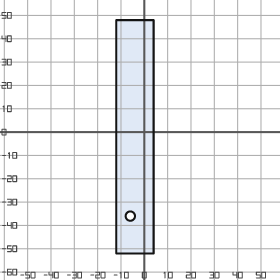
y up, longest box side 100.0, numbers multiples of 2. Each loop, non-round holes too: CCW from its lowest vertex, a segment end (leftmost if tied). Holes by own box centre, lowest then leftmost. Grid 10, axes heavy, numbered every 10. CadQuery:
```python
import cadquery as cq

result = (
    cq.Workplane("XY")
    .moveTo(-12.0, -52.0)
    .lineTo(4.0, -52.0)
    .lineTo(4.0, 48.0)
    .lineTo(-12.0, 48.0)
    .close()
    .moveTo(-6.0, -36.0)
    .circle(2.0)
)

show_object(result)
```